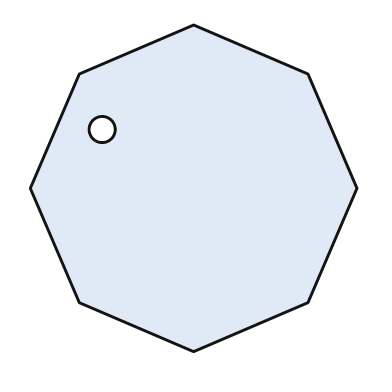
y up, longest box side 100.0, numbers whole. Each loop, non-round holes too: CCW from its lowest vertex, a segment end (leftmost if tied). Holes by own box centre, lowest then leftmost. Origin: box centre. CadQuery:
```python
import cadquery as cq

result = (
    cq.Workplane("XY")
    .moveTo(0.0, -50.0)
    .lineTo(35.0, -35.0)
    .lineTo(50.0, 0.0)
    .lineTo(35.0, 35.0)
    .lineTo(0.0, 50.0)
    .lineTo(-35.0, 35.0)
    .lineTo(-50.0, 0.0)
    .lineTo(-35.0, -35.0)
    .close()
    .moveTo(-28.0, 18.0)
    .circle(4.0)
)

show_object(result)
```